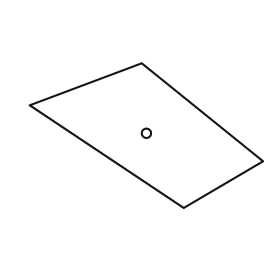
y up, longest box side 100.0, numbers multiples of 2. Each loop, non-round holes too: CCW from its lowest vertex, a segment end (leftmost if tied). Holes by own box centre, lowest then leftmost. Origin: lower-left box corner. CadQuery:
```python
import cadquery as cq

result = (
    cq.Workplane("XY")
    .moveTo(66.0, 0.0)
    .lineTo(100.0, 20.0)
    .lineTo(48.0, 62.0)
    .lineTo(0.0, 44.0)
    .close()
    .moveTo(50.0, 32.0)
    .circle(2.0)
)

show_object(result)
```